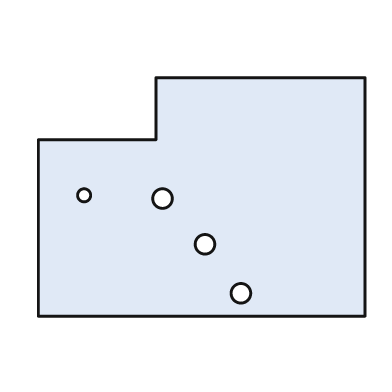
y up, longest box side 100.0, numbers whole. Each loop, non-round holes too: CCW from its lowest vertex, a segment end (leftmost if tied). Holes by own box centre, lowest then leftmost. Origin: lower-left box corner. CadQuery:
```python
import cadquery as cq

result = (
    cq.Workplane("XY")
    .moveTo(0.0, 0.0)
    .lineTo(100.0, 0.0)
    .lineTo(100.0, 73.0)
    .lineTo(36.0, 73.0)
    .lineTo(36.0, 54.0)
    .lineTo(0.0, 54.0)
    .close()
    .moveTo(62.0, 7.0)
    .circle(3.0)
    .moveTo(51.0, 22.0)
    .circle(3.0)
    .moveTo(38.0, 36.0)
    .circle(3.0)
    .moveTo(14.0, 37.0)
    .circle(2.0)
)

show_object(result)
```